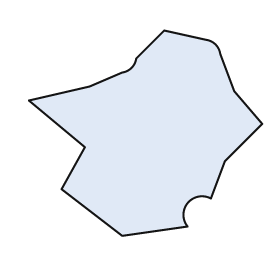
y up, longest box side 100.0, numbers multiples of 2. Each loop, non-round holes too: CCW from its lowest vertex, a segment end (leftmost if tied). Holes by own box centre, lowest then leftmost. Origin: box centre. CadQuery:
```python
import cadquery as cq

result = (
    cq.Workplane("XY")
    .moveTo(-10.0, -44.0)
    .lineTo(18.0, -40.0)
    .threePointArc((18.0, -30.0), (28.0, -28.0))
    .lineTo(34.0, -12.0)
    .lineTo(50.0, 4.0)
    .lineTo(38.0, 18.0)
    .lineTo(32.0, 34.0)
    .threePointArc((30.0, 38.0), (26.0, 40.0))
    .lineTo(8.0, 44.0)
    .lineTo(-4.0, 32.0)
    .threePointArc((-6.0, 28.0), (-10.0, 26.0))
    .lineTo(-24.0, 20.0)
    .lineTo(-50.0, 14.0)
    .lineTo(-26.0, -6.0)
    .lineTo(-36.0, -24.0)
    .close()
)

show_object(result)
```